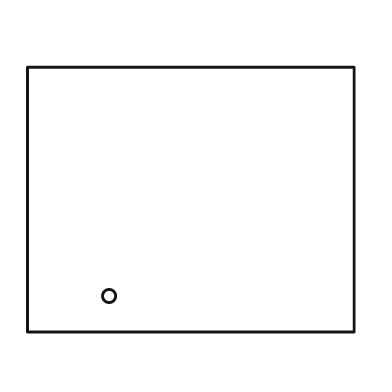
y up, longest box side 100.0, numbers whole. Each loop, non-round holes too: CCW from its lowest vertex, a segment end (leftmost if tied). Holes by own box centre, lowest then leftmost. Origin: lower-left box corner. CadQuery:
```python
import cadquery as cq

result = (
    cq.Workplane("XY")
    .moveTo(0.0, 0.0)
    .lineTo(100.0, 0.0)
    .lineTo(100.0, 81.0)
    .lineTo(0.0, 81.0)
    .close()
    .moveTo(25.0, 11.0)
    .circle(2.0)
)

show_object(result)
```